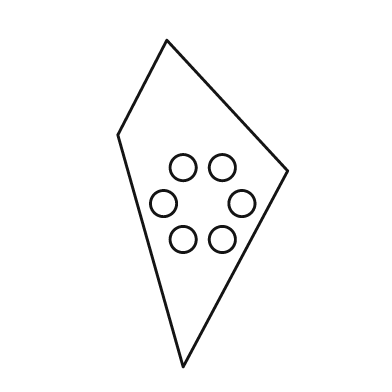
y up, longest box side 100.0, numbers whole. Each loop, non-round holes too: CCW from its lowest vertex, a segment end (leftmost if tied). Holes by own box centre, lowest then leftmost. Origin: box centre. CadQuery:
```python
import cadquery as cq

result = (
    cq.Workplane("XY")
    .moveTo(-6.0, -50.0)
    .lineTo(26.0, 10.0)
    .lineTo(-11.0, 50.0)
    .lineTo(-26.0, 21.0)
    .close()
    .moveTo(-6.0, -11.0)
    .circle(4.0)
    .moveTo(6.0, -11.0)
    .circle(4.0)
    .moveTo(-12.0, 0.0)
    .circle(4.0)
    .moveTo(12.0, 0.0)
    .circle(4.0)
    .moveTo(-6.0, 11.0)
    .circle(4.0)
    .moveTo(6.0, 11.0)
    .circle(4.0)
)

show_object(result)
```